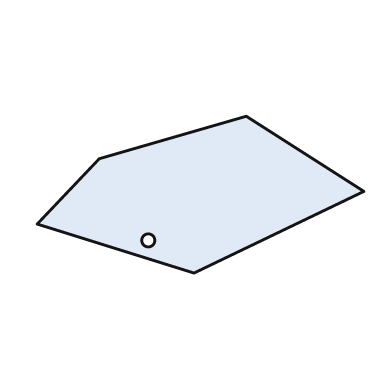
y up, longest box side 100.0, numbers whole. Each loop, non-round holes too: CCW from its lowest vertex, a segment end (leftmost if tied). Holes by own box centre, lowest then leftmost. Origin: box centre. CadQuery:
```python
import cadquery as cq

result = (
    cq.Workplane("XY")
    .moveTo(-2.0, -24.0)
    .lineTo(50.0, 1.0)
    .lineTo(14.0, 24.0)
    .lineTo(-31.0, 11.0)
    .lineTo(-50.0, -9.0)
    .close()
    .moveTo(-16.0, -14.0)
    .circle(2.0)
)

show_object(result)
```